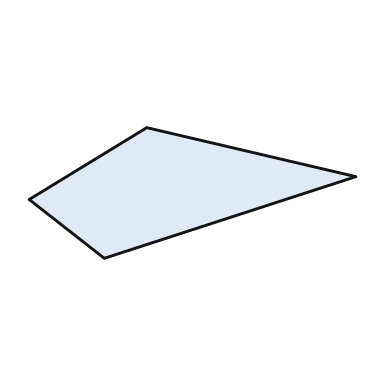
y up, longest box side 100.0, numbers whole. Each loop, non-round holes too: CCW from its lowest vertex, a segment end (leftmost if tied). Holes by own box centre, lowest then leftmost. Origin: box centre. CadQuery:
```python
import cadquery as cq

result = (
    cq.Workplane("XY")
    .moveTo(-27.0, -20.0)
    .lineTo(50.0, 5.0)
    .lineTo(-14.0, 20.0)
    .lineTo(-50.0, -2.0)
    .close()
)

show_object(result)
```